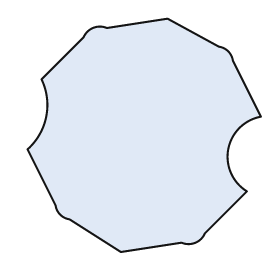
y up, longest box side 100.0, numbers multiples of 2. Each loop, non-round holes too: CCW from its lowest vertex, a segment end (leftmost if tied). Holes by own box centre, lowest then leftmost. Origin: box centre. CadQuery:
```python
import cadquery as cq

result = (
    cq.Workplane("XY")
    .moveTo(-10.0, -50.0)
    .lineTo(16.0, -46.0)
    .threePointArc((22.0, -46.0), (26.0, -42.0))
    .lineTo(44.0, -24.0)
    .threePointArc((36.0, -6.0), (50.0, 8.0))
    .lineTo(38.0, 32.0)
    .threePointArc((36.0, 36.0), (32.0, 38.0))
    .lineTo(10.0, 50.0)
    .lineTo(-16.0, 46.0)
    .threePointArc((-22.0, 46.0), (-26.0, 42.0))
    .lineTo(-44.0, 24.0)
    .threePointArc((-42.0, 8.0), (-50.0, -6.0))
    .lineTo(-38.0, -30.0)
    .threePointArc((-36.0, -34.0), (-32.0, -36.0))
    .close()
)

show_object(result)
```